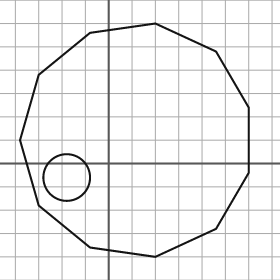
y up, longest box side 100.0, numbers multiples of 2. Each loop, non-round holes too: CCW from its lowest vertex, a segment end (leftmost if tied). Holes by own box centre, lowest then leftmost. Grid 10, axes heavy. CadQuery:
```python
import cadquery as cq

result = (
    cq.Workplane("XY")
    .moveTo(20.0, -40.0)
    .lineTo(46.0, -28.0)
    .lineTo(60.0, -4.0)
    .lineTo(60.0, 24.0)
    .lineTo(46.0, 48.0)
    .lineTo(20.0, 60.0)
    .lineTo(-8.0, 56.0)
    .lineTo(-30.0, 38.0)
    .lineTo(-38.0, 10.0)
    .lineTo(-30.0, -18.0)
    .lineTo(-8.0, -36.0)
    .close()
    .moveTo(-18.0, -6.0)
    .circle(10.0)
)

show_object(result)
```